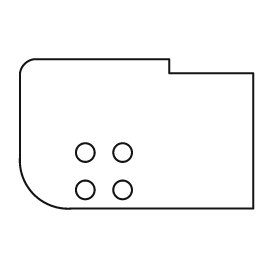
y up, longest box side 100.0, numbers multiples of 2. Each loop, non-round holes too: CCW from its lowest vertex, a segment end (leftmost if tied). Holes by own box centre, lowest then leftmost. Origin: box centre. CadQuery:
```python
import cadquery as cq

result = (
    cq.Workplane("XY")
    .moveTo(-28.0, -32.0)
    .lineTo(50.0, -32.0)
    .lineTo(50.0, 26.0)
    .lineTo(14.0, 26.0)
    .lineTo(14.0, 32.0)
    .lineTo(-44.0, 32.0)
    .threePointArc((-48.0, 30.0), (-50.0, 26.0))
    .lineTo(-50.0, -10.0)
    .threePointArc((-44.0, -26.0), (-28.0, -32.0))
    .close()
    .moveTo(-22.0, -24.0)
    .circle(4.0)
    .moveTo(-6.0, -24.0)
    .circle(4.0)
    .moveTo(-22.0, -8.0)
    .circle(4.0)
    .moveTo(-6.0, -8.0)
    .circle(4.0)
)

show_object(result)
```